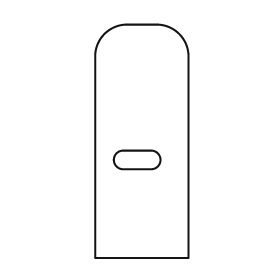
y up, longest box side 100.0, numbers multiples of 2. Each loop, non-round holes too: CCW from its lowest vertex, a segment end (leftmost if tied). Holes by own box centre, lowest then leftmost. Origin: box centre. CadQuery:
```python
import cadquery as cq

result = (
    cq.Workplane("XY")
    .moveTo(-20.0, -50.0)
    .lineTo(20.0, -50.0)
    .lineTo(20.0, 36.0)
    .threePointArc((16.0, 46.0), (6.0, 50.0))
    .lineTo(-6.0, 50.0)
    .threePointArc((-16.0, 46.0), (-20.0, 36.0))
    .close()
    .moveTo(-8.0, -12.0)
    .lineTo(4.0, -12.0)
    .threePointArc((8.0, -8.0), (4.0, -4.0))
    .lineTo(-8.0, -4.0)
    .threePointArc((-12.0, -8.0), (-8.0, -12.0))
    .close()
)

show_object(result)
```